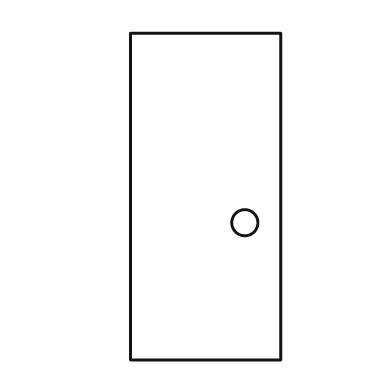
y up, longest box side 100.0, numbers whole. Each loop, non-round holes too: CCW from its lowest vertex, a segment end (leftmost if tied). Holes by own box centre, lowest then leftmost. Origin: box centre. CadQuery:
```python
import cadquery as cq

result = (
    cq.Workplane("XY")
    .moveTo(-23.0, -50.0)
    .lineTo(23.0, -50.0)
    .lineTo(23.0, 50.0)
    .lineTo(-23.0, 50.0)
    .close()
    .moveTo(12.0, -8.0)
    .circle(4.0)
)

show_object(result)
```